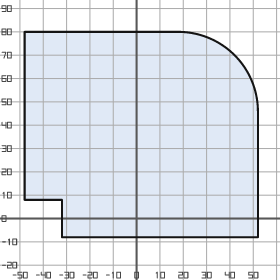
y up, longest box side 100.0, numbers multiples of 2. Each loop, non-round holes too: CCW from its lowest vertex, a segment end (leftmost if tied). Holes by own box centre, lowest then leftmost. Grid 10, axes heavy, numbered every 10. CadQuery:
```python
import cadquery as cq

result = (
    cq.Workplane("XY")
    .moveTo(-32.0, -8.0)
    .lineTo(52.0, -8.0)
    .lineTo(52.0, 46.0)
    .threePointArc((42.0, 70.0), (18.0, 80.0))
    .lineTo(-48.0, 80.0)
    .lineTo(-48.0, 8.0)
    .lineTo(-32.0, 8.0)
    .close()
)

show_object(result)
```